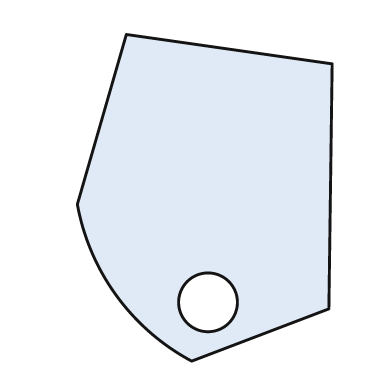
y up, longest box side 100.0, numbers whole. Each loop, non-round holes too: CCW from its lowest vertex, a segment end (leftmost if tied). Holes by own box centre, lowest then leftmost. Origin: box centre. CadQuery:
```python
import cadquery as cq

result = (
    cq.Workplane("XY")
    .moveTo(-4.0, -50.0)
    .lineTo(38.0, -34.0)
    .lineTo(39.0, 41.0)
    .lineTo(-24.0, 50.0)
    .lineTo(-39.0, -2.0)
    .threePointArc((-27.0, -30.0), (-4.0, -50.0))
    .close()
    .moveTo(1.0, -32.0)
    .circle(9.0)
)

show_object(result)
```